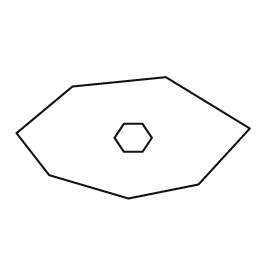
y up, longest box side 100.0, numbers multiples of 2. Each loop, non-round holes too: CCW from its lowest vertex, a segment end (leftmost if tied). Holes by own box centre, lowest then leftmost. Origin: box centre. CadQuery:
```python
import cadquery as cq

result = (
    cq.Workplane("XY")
    .moveTo(-2.0, -26.0)
    .lineTo(28.0, -20.0)
    .lineTo(50.0, 4.0)
    .lineTo(14.0, 26.0)
    .lineTo(-26.0, 22.0)
    .lineTo(-50.0, 2.0)
    .lineTo(-36.0, -16.0)
    .close()
    .moveTo(-4.0, -6.0)
    .lineTo(4.0, -6.0)
    .lineTo(8.0, 0.0)
    .lineTo(4.0, 6.0)
    .lineTo(-4.0, 6.0)
    .lineTo(-8.0, 0.0)
    .close()
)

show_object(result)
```